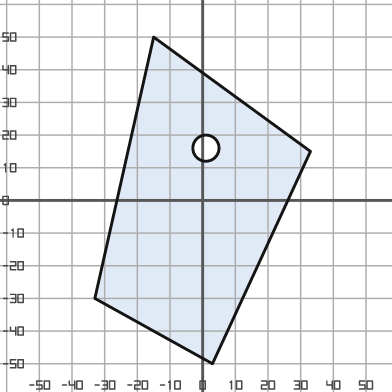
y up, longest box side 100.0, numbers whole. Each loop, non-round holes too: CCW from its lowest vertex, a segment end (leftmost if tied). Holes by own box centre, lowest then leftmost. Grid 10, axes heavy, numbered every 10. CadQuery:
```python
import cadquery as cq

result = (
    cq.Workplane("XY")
    .moveTo(3.0, -50.0)
    .lineTo(33.0, 15.0)
    .lineTo(-15.0, 50.0)
    .lineTo(-33.0, -30.0)
    .close()
    .moveTo(1.0, 16.0)
    .circle(4.0)
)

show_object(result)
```